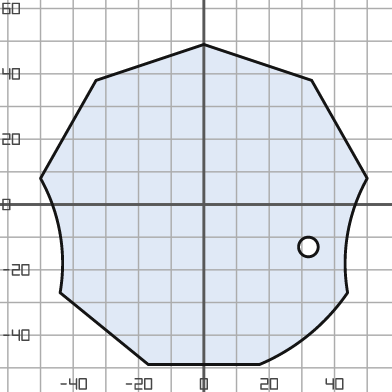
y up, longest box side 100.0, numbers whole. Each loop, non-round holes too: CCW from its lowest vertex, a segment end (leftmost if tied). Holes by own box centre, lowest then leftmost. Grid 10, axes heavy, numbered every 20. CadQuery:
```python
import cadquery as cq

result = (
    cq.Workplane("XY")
    .moveTo(-17.0, -49.0)
    .lineTo(17.0, -49.0)
    .threePointArc((32.0, -40.0), (44.0, -27.0))
    .threePointArc((44.0, -9.0), (50.0, 8.0))
    .lineTo(33.0, 38.0)
    .lineTo(0.0, 49.0)
    .lineTo(-33.0, 38.0)
    .lineTo(-50.0, 8.0)
    .threePointArc((-44.0, -9.0), (-44.0, -27.0))
    .close()
    .moveTo(32.0, -13.0)
    .circle(3.0)
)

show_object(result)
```